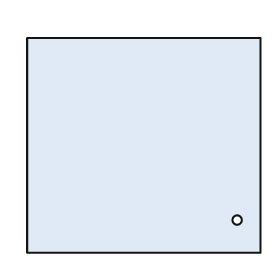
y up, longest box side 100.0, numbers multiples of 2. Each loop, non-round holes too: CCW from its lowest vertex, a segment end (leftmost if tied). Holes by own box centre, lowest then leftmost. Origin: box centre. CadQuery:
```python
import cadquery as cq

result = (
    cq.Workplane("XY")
    .moveTo(-50.0, -46.0)
    .lineTo(50.0, -46.0)
    .lineTo(50.0, 46.0)
    .lineTo(-50.0, 46.0)
    .close()
    .moveTo(40.0, -32.0)
    .circle(2.0)
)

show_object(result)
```